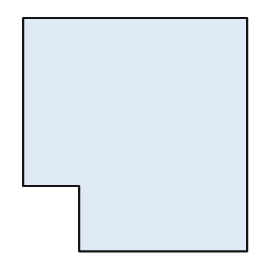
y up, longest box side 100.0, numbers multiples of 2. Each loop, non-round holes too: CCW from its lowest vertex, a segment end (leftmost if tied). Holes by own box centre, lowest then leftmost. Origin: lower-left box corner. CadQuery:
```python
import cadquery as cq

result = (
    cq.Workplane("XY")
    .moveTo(24.0, 0.0)
    .lineTo(96.0, 0.0)
    .lineTo(96.0, 100.0)
    .lineTo(0.0, 100.0)
    .lineTo(0.0, 28.0)
    .lineTo(24.0, 28.0)
    .close()
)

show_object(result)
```